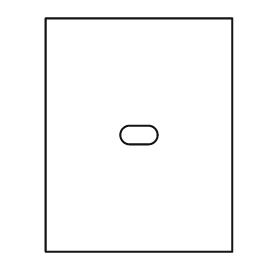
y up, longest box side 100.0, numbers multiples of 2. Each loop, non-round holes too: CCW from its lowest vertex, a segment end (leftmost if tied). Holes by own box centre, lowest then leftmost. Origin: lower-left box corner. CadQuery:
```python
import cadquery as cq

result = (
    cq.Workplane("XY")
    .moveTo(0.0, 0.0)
    .lineTo(80.0, 0.0)
    .lineTo(80.0, 100.0)
    .lineTo(0.0, 100.0)
    .close()
    .moveTo(36.0, 46.0)
    .lineTo(44.0, 46.0)
    .threePointArc((48.0, 50.0), (44.0, 54.0))
    .lineTo(36.0, 54.0)
    .threePointArc((32.0, 50.0), (36.0, 46.0))
    .close()
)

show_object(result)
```